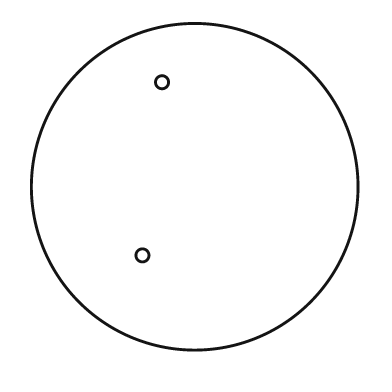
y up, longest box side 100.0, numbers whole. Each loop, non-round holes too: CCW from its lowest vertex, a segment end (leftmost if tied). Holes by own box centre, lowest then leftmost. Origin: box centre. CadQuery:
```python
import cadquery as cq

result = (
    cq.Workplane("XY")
    .moveTo(0.0, 0.0)
    .circle(50.0)
    .moveTo(-16.0, -21.0)
    .circle(2.0)
    .moveTo(-10.0, 32.0)
    .circle(2.0)
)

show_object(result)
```